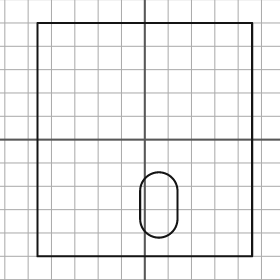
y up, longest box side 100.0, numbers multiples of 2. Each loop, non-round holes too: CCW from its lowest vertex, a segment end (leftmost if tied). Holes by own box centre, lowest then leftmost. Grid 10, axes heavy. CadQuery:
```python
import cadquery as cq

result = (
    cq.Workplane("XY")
    .moveTo(-46.0, -50.0)
    .lineTo(46.0, -50.0)
    .lineTo(46.0, 50.0)
    .lineTo(-46.0, 50.0)
    .close()
    .moveTo(-2.0, -34.0)
    .threePointArc((6.0, -42.0), (14.0, -34.0))
    .lineTo(14.0, -22.0)
    .threePointArc((6.0, -14.0), (-2.0, -22.0))
    .close()
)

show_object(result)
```